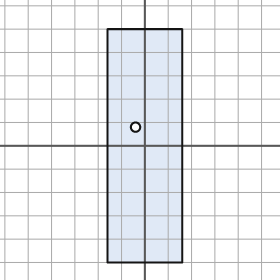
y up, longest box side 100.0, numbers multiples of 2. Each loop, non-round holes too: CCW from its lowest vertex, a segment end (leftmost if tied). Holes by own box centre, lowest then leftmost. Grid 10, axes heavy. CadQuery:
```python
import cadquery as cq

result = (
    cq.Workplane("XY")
    .moveTo(-16.0, -50.0)
    .lineTo(16.0, -50.0)
    .lineTo(16.0, 50.0)
    .lineTo(-16.0, 50.0)
    .close()
    .moveTo(-4.0, 8.0)
    .circle(2.0)
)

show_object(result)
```